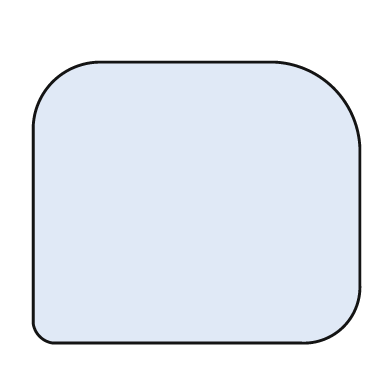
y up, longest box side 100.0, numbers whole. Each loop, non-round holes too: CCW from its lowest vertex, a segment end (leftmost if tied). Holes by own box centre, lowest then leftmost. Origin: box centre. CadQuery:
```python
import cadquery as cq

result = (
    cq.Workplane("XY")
    .moveTo(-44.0, -43.0)
    .lineTo(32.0, -43.0)
    .threePointArc((45.0, -38.0), (50.0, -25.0))
    .lineTo(50.0, 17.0)
    .threePointArc((42.0, 35.0), (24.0, 43.0))
    .lineTo(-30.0, 43.0)
    .threePointArc((-44.0, 37.0), (-50.0, 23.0))
    .lineTo(-50.0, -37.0)
    .threePointArc((-48.0, -41.0), (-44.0, -43.0))
    .close()
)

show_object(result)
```